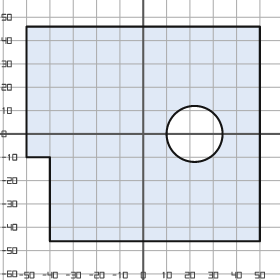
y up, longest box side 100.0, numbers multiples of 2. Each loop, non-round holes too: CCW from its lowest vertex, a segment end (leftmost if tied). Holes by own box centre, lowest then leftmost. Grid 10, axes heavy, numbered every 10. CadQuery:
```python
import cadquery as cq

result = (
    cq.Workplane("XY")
    .moveTo(-40.0, -46.0)
    .lineTo(50.0, -46.0)
    .lineTo(50.0, 46.0)
    .lineTo(-50.0, 46.0)
    .lineTo(-50.0, -10.0)
    .lineTo(-40.0, -10.0)
    .close()
    .moveTo(22.0, 0.0)
    .circle(12.0)
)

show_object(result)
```